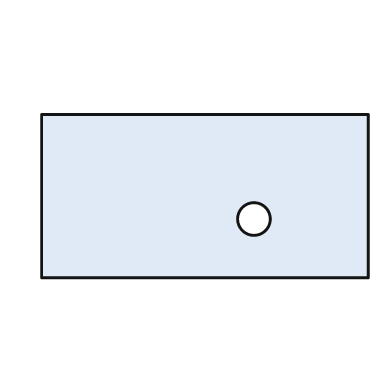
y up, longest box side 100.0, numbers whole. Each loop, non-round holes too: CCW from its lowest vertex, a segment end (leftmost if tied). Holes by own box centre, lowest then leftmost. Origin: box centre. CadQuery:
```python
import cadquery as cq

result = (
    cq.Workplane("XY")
    .moveTo(-50.0, -25.0)
    .lineTo(50.0, -25.0)
    .lineTo(50.0, 25.0)
    .lineTo(-50.0, 25.0)
    .close()
    .moveTo(15.0, -7.0)
    .circle(5.0)
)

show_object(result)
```